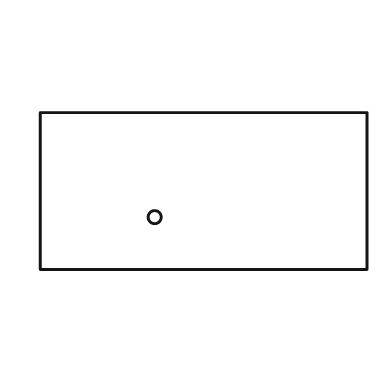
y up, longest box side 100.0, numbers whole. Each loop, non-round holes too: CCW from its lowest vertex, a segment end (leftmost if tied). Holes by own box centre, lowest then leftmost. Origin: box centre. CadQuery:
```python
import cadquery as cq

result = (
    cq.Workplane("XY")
    .moveTo(-50.0, -24.0)
    .lineTo(50.0, -24.0)
    .lineTo(50.0, 24.0)
    .lineTo(-50.0, 24.0)
    .close()
    .moveTo(-15.0, -8.0)
    .circle(2.0)
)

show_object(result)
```